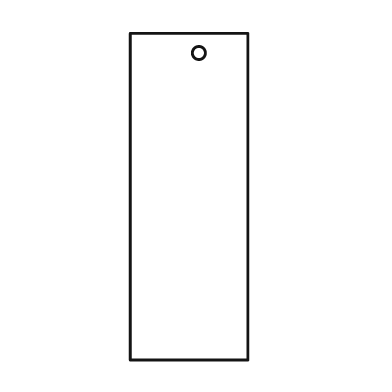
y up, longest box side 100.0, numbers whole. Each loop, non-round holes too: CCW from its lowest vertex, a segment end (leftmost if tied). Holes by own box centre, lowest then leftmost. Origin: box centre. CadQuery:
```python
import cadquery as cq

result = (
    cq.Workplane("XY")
    .moveTo(-18.0, -50.0)
    .lineTo(18.0, -50.0)
    .lineTo(18.0, 50.0)
    .lineTo(-18.0, 50.0)
    .close()
    .moveTo(3.0, 44.0)
    .circle(2.0)
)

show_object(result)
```